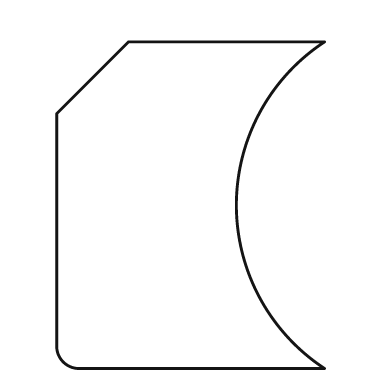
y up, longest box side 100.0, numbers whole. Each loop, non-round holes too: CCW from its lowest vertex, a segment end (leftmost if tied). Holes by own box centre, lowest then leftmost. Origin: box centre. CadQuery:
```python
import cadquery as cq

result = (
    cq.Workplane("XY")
    .moveTo(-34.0, -50.0)
    .lineTo(41.0, -50.0)
    .threePointArc((14.0, 0.0), (41.0, 50.0))
    .lineTo(-19.0, 50.0)
    .lineTo(-41.0, 28.0)
    .lineTo(-41.0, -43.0)
    .threePointArc((-39.0, -48.0), (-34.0, -50.0))
    .close()
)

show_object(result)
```